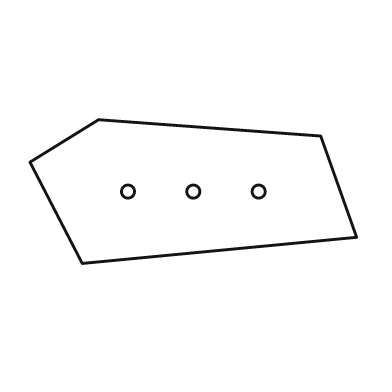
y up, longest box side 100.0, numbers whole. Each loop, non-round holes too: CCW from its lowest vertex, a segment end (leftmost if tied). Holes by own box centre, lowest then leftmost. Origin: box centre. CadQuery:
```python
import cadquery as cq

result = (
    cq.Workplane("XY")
    .moveTo(-34.0, -22.0)
    .lineTo(50.0, -14.0)
    .lineTo(39.0, 17.0)
    .lineTo(-29.0, 22.0)
    .lineTo(-50.0, 9.0)
    .close()
    .moveTo(-20.0, 0.0)
    .circle(2.0)
    .moveTo(0.0, 0.0)
    .circle(2.0)
    .moveTo(20.0, 0.0)
    .circle(2.0)
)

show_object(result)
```